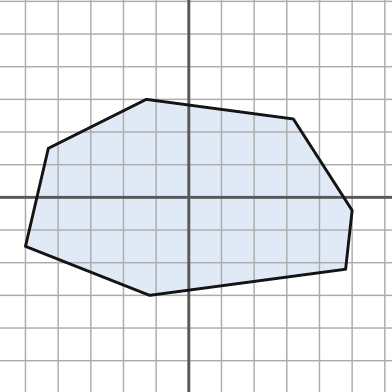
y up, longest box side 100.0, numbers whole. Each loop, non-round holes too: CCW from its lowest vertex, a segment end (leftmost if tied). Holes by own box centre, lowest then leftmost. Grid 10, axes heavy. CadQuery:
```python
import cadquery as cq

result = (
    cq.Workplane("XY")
    .moveTo(-12.0, -30.0)
    .lineTo(48.0, -22.0)
    .lineTo(50.0, -4.0)
    .lineTo(32.0, 24.0)
    .lineTo(-13.0, 30.0)
    .lineTo(-43.0, 15.0)
    .lineTo(-50.0, -15.0)
    .close()
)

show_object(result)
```